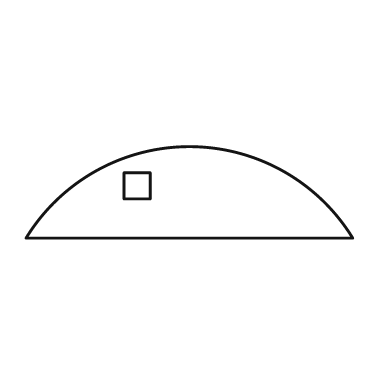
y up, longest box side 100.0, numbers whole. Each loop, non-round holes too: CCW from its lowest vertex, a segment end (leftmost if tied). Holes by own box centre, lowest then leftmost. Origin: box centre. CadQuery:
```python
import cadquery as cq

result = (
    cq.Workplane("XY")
    .moveTo(-50.0, -14.0)
    .lineTo(50.0, -14.0)
    .threePointArc((0.0, 14.0), (-50.0, -14.0))
    .close()
    .moveTo(-20.0, -2.0)
    .lineTo(-12.0, -2.0)
    .lineTo(-12.0, 6.0)
    .lineTo(-20.0, 6.0)
    .close()
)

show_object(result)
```